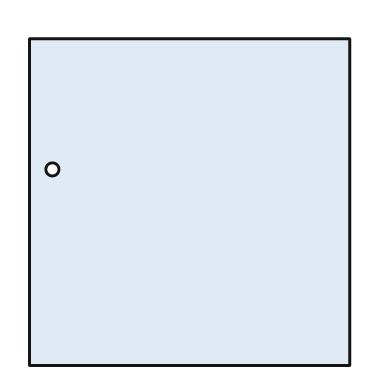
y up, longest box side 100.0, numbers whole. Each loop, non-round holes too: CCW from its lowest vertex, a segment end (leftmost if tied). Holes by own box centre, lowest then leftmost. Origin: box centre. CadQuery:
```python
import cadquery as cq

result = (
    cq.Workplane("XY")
    .moveTo(-49.0, -50.0)
    .lineTo(49.0, -50.0)
    .lineTo(49.0, 50.0)
    .lineTo(-49.0, 50.0)
    .close()
    .moveTo(-42.0, 10.0)
    .circle(2.0)
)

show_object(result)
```